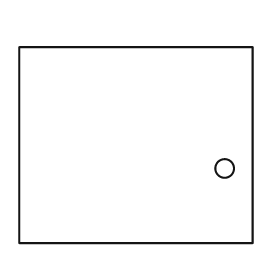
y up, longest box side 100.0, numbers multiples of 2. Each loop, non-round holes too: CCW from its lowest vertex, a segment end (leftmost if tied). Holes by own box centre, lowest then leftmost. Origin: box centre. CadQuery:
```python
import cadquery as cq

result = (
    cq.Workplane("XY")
    .moveTo(-50.0, -42.0)
    .lineTo(50.0, -42.0)
    .lineTo(50.0, 42.0)
    .lineTo(-50.0, 42.0)
    .close()
    .moveTo(38.0, -10.0)
    .circle(4.0)
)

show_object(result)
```